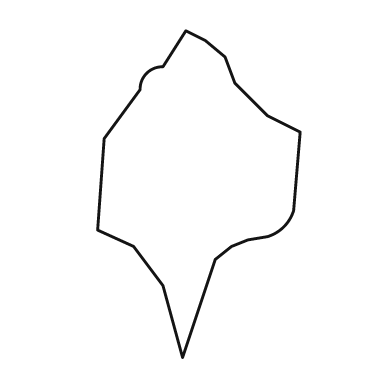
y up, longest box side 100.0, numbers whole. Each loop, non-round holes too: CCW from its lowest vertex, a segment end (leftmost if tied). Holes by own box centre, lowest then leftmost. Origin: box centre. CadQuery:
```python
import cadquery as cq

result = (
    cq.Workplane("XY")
    .moveTo(-5.0, -50.0)
    .lineTo(5.0, -20.0)
    .lineTo(10.0, -16.0)
    .lineTo(15.0, -14.0)
    .lineTo(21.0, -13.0)
    .threePointArc((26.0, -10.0), (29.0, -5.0))
    .lineTo(31.0, 19.0)
    .lineTo(21.0, 24.0)
    .lineTo(11.0, 34.0)
    .lineTo(8.0, 42.0)
    .lineTo(2.0, 47.0)
    .lineTo(-4.0, 50.0)
    .lineTo(-11.0, 39.0)
    .threePointArc((-16.0, 37.0), (-18.0, 32.0))
    .lineTo(-29.0, 17.0)
    .lineTo(-31.0, -11.0)
    .lineTo(-20.0, -16.0)
    .lineTo(-11.0, -28.0)
    .close()
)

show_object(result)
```